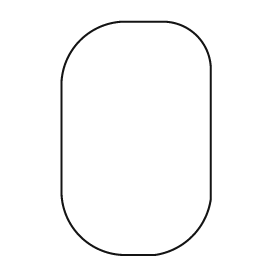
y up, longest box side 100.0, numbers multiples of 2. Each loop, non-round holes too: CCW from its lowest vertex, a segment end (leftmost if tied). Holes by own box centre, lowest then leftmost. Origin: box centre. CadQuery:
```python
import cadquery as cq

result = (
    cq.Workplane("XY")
    .moveTo(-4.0, -50.0)
    .lineTo(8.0, -50.0)
    .threePointArc((24.0, -42.0), (32.0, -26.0))
    .lineTo(32.0, 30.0)
    .threePointArc((26.0, 44.0), (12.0, 50.0))
    .lineTo(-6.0, 50.0)
    .threePointArc((-24.0, 42.0), (-32.0, 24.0))
    .lineTo(-32.0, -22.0)
    .threePointArc((-24.0, -42.0), (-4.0, -50.0))
    .close()
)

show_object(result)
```